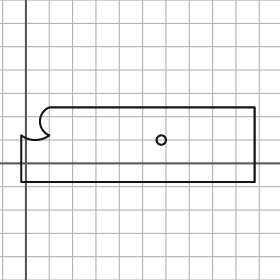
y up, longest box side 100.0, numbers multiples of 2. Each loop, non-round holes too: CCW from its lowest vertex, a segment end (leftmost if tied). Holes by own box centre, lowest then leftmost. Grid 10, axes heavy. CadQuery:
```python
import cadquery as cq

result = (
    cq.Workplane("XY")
    .moveTo(-2.0, -8.0)
    .lineTo(98.0, -8.0)
    .lineTo(98.0, 24.0)
    .lineTo(10.0, 24.0)
    .threePointArc((6.0, 18.0), (10.0, 12.0))
    .threePointArc((4.0, 10.0), (-2.0, 12.0))
    .close()
    .moveTo(58.0, 10.0)
    .circle(2.0)
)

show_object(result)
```